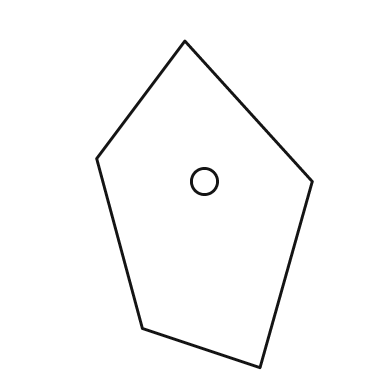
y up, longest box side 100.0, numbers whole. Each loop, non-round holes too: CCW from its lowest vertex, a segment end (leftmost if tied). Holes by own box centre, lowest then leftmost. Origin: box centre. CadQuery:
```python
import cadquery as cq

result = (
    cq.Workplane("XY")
    .moveTo(17.0, -50.0)
    .lineTo(33.0, 7.0)
    .lineTo(-6.0, 50.0)
    .lineTo(-33.0, 14.0)
    .lineTo(-19.0, -38.0)
    .close()
    .moveTo(0.0, 7.0)
    .circle(4.0)
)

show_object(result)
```